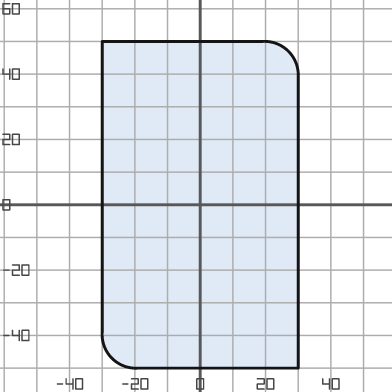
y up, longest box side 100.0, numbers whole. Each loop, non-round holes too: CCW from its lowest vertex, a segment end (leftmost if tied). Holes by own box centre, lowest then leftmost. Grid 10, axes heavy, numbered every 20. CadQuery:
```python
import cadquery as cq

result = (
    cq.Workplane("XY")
    .moveTo(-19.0, -50.0)
    .lineTo(30.0, -50.0)
    .lineTo(30.0, 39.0)
    .threePointArc((27.0, 47.0), (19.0, 50.0))
    .lineTo(-30.0, 50.0)
    .lineTo(-30.0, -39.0)
    .threePointArc((-27.0, -47.0), (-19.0, -50.0))
    .close()
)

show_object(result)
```